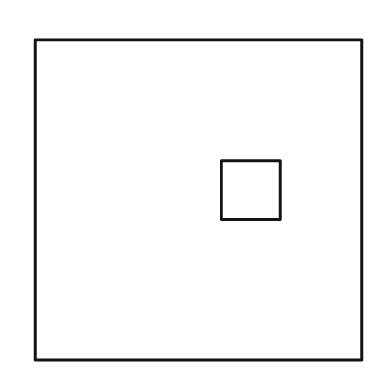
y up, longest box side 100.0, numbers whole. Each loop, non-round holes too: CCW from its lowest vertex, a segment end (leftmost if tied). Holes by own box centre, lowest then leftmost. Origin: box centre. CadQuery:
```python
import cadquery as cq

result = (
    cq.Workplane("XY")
    .moveTo(-50.0, -49.0)
    .lineTo(50.0, -49.0)
    .lineTo(50.0, 49.0)
    .lineTo(-50.0, 49.0)
    .close()
    .moveTo(7.0, -6.0)
    .lineTo(25.0, -6.0)
    .lineTo(25.0, 12.0)
    .lineTo(7.0, 12.0)
    .close()
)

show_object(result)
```